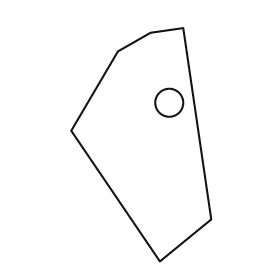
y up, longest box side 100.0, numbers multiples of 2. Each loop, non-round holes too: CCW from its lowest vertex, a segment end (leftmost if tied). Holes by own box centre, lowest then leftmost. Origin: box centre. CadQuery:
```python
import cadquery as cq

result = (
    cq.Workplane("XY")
    .moveTo(8.0, -50.0)
    .lineTo(30.0, -32.0)
    .lineTo(18.0, 50.0)
    .lineTo(4.0, 48.0)
    .lineTo(-10.0, 40.0)
    .lineTo(-30.0, 6.0)
    .close()
    .moveTo(12.0, 18.0)
    .circle(6.0)
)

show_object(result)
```